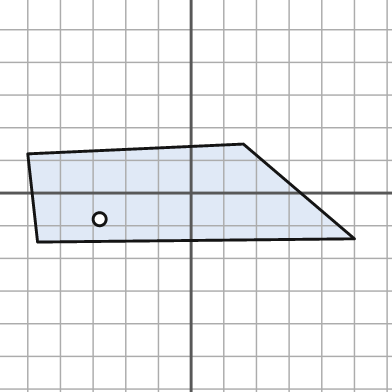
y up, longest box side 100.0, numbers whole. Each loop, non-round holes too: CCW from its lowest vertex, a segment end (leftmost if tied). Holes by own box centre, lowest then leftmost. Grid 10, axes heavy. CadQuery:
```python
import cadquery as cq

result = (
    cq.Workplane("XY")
    .moveTo(-47.0, -15.0)
    .lineTo(50.0, -14.0)
    .lineTo(16.0, 15.0)
    .lineTo(-50.0, 12.0)
    .close()
    .moveTo(-28.0, -8.0)
    .circle(2.0)
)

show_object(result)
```